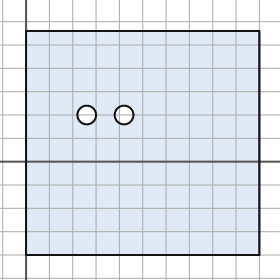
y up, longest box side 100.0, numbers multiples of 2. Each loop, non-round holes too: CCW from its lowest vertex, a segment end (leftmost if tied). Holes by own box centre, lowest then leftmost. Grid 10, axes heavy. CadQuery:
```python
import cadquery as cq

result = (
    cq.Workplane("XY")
    .moveTo(0.0, -40.0)
    .lineTo(100.0, -40.0)
    .lineTo(100.0, 56.0)
    .lineTo(0.0, 56.0)
    .close()
    .moveTo(26.0, 20.0)
    .circle(4.0)
    .moveTo(42.0, 20.0)
    .circle(4.0)
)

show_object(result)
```